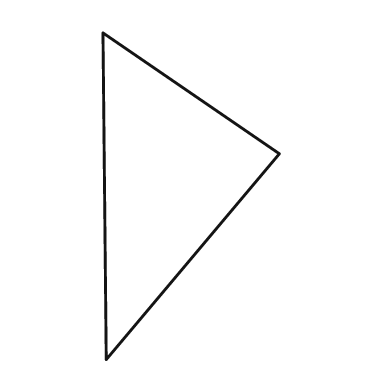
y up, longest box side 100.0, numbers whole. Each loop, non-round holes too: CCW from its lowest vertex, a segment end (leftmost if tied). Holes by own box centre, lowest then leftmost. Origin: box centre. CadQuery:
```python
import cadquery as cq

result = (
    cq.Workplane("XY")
    .moveTo(-26.0, -50.0)
    .lineTo(27.0, 13.0)
    .lineTo(-27.0, 50.0)
    .close()
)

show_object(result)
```